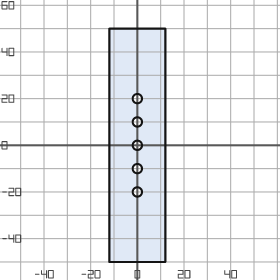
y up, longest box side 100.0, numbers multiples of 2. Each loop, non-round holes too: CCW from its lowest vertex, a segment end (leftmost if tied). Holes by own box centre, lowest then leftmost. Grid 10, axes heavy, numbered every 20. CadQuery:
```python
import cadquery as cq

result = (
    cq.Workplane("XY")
    .moveTo(-12.0, -50.0)
    .lineTo(12.0, -50.0)
    .lineTo(12.0, 50.0)
    .lineTo(-12.0, 50.0)
    .close()
    .moveTo(0.0, -20.0)
    .circle(2.0)
    .moveTo(0.0, -10.0)
    .circle(2.0)
    .moveTo(0.0, 0.0)
    .circle(2.0)
    .moveTo(0.0, 10.0)
    .circle(2.0)
    .moveTo(0.0, 20.0)
    .circle(2.0)
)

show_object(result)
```